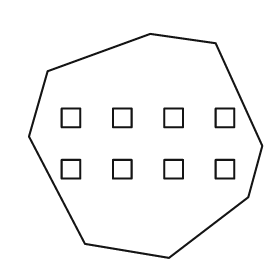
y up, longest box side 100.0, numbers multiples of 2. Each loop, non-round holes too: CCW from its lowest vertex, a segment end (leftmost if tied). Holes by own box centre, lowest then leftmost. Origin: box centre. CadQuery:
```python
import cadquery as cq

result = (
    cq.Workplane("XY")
    .moveTo(10.0, -48.0)
    .lineTo(44.0, -22.0)
    .lineTo(50.0, 0.0)
    .lineTo(30.0, 44.0)
    .lineTo(2.0, 48.0)
    .lineTo(-42.0, 32.0)
    .lineTo(-50.0, 4.0)
    .lineTo(-26.0, -42.0)
    .close()
    .moveTo(-36.0, -14.0)
    .lineTo(-28.0, -14.0)
    .lineTo(-28.0, -6.0)
    .lineTo(-36.0, -6.0)
    .close()
    .moveTo(-14.0, -14.0)
    .lineTo(-6.0, -14.0)
    .lineTo(-6.0, -6.0)
    .lineTo(-14.0, -6.0)
    .close()
    .moveTo(8.0, -14.0)
    .lineTo(16.0, -14.0)
    .lineTo(16.0, -6.0)
    .lineTo(8.0, -6.0)
    .close()
    .moveTo(30.0, -14.0)
    .lineTo(38.0, -14.0)
    .lineTo(38.0, -6.0)
    .lineTo(30.0, -6.0)
    .close()
    .moveTo(-36.0, 8.0)
    .lineTo(-28.0, 8.0)
    .lineTo(-28.0, 16.0)
    .lineTo(-36.0, 16.0)
    .close()
    .moveTo(-14.0, 8.0)
    .lineTo(-6.0, 8.0)
    .lineTo(-6.0, 16.0)
    .lineTo(-14.0, 16.0)
    .close()
    .moveTo(8.0, 8.0)
    .lineTo(16.0, 8.0)
    .lineTo(16.0, 16.0)
    .lineTo(8.0, 16.0)
    .close()
    .moveTo(30.0, 8.0)
    .lineTo(38.0, 8.0)
    .lineTo(38.0, 16.0)
    .lineTo(30.0, 16.0)
    .close()
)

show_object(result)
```